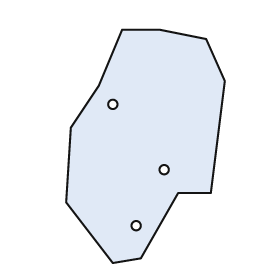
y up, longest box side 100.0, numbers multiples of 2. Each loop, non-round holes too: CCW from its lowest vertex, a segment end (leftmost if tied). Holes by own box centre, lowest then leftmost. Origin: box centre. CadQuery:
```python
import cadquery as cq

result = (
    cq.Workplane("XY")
    .moveTo(-14.0, -50.0)
    .lineTo(-2.0, -48.0)
    .lineTo(14.0, -20.0)
    .lineTo(28.0, -20.0)
    .lineTo(34.0, 28.0)
    .lineTo(26.0, 46.0)
    .lineTo(6.0, 50.0)
    .lineTo(-10.0, 50.0)
    .lineTo(-20.0, 26.0)
    .lineTo(-32.0, 8.0)
    .lineTo(-34.0, -24.0)
    .close()
    .moveTo(-4.0, -34.0)
    .circle(2.0)
    .moveTo(8.0, -10.0)
    .circle(2.0)
    .moveTo(-14.0, 18.0)
    .circle(2.0)
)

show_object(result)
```